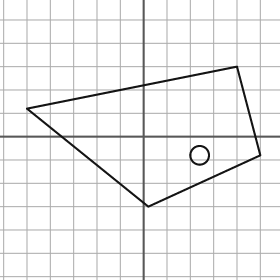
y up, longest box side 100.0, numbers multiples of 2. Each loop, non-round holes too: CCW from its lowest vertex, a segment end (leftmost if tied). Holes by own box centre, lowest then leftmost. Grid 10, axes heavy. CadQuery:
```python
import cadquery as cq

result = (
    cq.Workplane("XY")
    .moveTo(2.0, -30.0)
    .lineTo(50.0, -8.0)
    .lineTo(40.0, 30.0)
    .lineTo(-50.0, 12.0)
    .close()
    .moveTo(24.0, -8.0)
    .circle(4.0)
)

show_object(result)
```